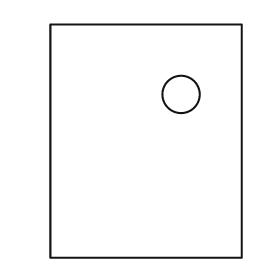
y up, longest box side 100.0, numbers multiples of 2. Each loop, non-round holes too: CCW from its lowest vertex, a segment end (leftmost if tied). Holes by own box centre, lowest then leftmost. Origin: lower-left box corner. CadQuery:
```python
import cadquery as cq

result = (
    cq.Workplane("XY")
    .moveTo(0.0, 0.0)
    .lineTo(82.0, 0.0)
    .lineTo(82.0, 100.0)
    .lineTo(0.0, 100.0)
    .close()
    .moveTo(56.0, 70.0)
    .circle(8.0)
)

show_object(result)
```